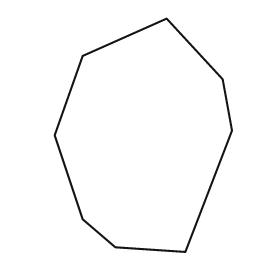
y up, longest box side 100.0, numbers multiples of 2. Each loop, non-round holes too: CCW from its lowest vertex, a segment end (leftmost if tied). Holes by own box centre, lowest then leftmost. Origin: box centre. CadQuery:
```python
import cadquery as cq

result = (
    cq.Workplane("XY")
    .moveTo(18.0, -50.0)
    .lineTo(38.0, 2.0)
    .lineTo(34.0, 24.0)
    .lineTo(10.0, 50.0)
    .lineTo(-26.0, 34.0)
    .lineTo(-38.0, 0.0)
    .lineTo(-26.0, -36.0)
    .lineTo(-12.0, -48.0)
    .close()
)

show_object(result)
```